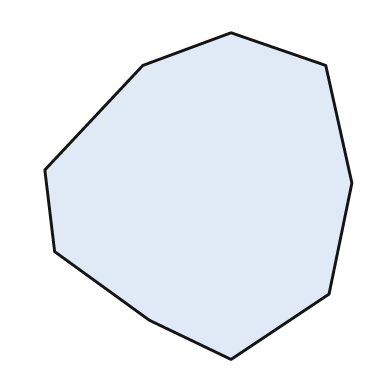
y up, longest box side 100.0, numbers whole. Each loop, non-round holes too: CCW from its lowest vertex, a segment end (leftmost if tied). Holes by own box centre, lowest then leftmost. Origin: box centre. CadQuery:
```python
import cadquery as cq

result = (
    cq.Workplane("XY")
    .moveTo(10.0, -50.0)
    .lineTo(40.0, -30.0)
    .lineTo(47.0, 4.0)
    .lineTo(39.0, 40.0)
    .lineTo(10.0, 50.0)
    .lineTo(-17.0, 40.0)
    .lineTo(-47.0, 8.0)
    .lineTo(-44.0, -17.0)
    .lineTo(-15.0, -38.0)
    .close()
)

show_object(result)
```